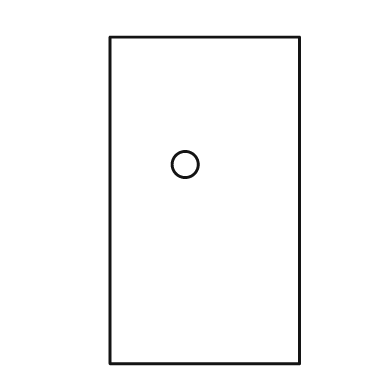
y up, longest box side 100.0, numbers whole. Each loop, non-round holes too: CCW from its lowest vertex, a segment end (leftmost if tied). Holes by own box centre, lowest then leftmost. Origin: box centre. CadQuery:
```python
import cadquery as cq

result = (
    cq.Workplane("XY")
    .moveTo(-29.0, -50.0)
    .lineTo(29.0, -50.0)
    .lineTo(29.0, 50.0)
    .lineTo(-29.0, 50.0)
    .close()
    .moveTo(-6.0, 11.0)
    .circle(4.0)
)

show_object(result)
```